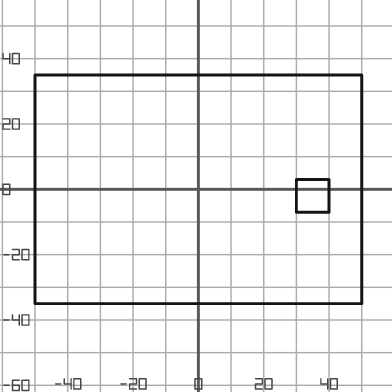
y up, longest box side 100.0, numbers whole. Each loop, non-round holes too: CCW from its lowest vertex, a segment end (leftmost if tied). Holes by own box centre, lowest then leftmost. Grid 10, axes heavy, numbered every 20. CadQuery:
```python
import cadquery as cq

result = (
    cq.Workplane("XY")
    .moveTo(-50.0, -35.0)
    .lineTo(50.0, -35.0)
    .lineTo(50.0, 35.0)
    .lineTo(-50.0, 35.0)
    .close()
    .moveTo(30.0, -7.0)
    .lineTo(40.0, -7.0)
    .lineTo(40.0, 3.0)
    .lineTo(30.0, 3.0)
    .close()
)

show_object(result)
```